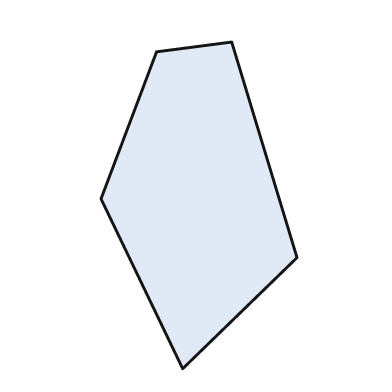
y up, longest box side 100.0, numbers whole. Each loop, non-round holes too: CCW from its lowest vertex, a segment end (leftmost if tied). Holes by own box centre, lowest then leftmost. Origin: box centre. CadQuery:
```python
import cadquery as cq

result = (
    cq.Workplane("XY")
    .moveTo(-5.0, -50.0)
    .lineTo(30.0, -16.0)
    .lineTo(10.0, 50.0)
    .lineTo(-13.0, 47.0)
    .lineTo(-30.0, 2.0)
    .close()
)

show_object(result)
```